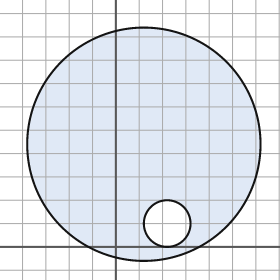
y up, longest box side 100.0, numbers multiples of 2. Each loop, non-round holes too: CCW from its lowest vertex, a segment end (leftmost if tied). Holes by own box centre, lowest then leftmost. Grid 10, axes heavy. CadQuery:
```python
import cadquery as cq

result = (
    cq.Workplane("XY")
    .moveTo(12.0, 44.0)
    .circle(50.0)
    .moveTo(22.0, 10.0)
    .circle(10.0)
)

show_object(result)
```